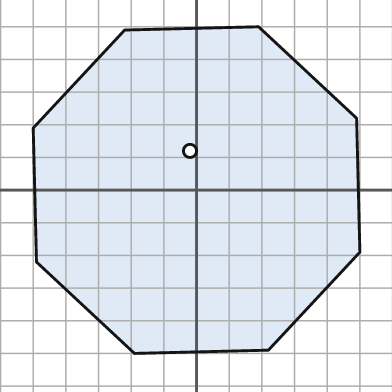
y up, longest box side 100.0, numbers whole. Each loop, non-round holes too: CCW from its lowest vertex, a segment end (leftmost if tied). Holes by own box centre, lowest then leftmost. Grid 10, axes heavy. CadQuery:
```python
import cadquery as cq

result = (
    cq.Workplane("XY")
    .moveTo(-19.0, -50.0)
    .lineTo(22.0, -49.0)
    .lineTo(50.0, -19.0)
    .lineTo(49.0, 22.0)
    .lineTo(19.0, 50.0)
    .lineTo(-22.0, 49.0)
    .lineTo(-50.0, 19.0)
    .lineTo(-49.0, -22.0)
    .close()
    .moveTo(-2.0, 12.0)
    .circle(2.0)
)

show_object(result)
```